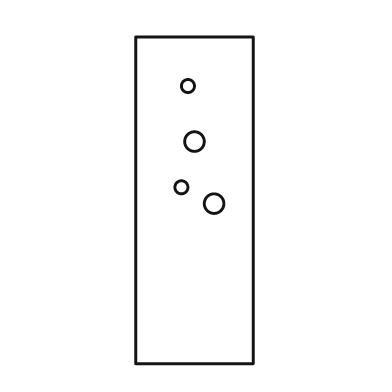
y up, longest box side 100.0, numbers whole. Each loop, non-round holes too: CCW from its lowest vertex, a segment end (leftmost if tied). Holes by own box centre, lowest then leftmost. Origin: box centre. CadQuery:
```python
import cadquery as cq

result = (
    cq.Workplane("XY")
    .moveTo(-18.0, -50.0)
    .lineTo(18.0, -50.0)
    .lineTo(18.0, 50.0)
    .lineTo(-18.0, 50.0)
    .close()
    .moveTo(6.0, -1.0)
    .circle(3.0)
    .moveTo(-4.0, 4.0)
    .circle(2.0)
    .moveTo(0.0, 18.0)
    .circle(3.0)
    .moveTo(-2.0, 35.0)
    .circle(2.0)
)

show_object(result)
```